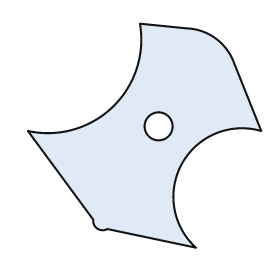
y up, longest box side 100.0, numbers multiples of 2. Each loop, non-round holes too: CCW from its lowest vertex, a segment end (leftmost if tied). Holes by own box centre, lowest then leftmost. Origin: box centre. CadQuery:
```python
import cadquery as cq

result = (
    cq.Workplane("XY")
    .moveTo(22.0, -48.0)
    .threePointArc((16.0, -12.0), (50.0, 2.0))
    .lineTo(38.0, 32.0)
    .threePointArc((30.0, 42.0), (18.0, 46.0))
    .lineTo(-2.0, 48.0)
    .threePointArc((-14.0, 12.0), (-50.0, 2.0))
    .lineTo(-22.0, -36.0)
    .threePointArc((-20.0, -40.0), (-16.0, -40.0))
    .close()
    .moveTo(6.0, 4.0)
    .circle(6.0)
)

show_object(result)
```